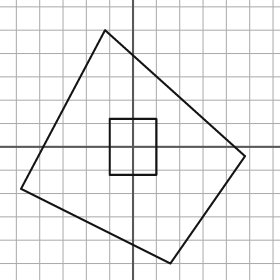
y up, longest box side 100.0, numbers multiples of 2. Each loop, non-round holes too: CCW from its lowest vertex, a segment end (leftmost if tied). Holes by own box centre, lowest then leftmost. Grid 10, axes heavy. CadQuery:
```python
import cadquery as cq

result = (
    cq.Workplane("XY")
    .moveTo(16.0, -50.0)
    .lineTo(48.0, -4.0)
    .lineTo(-12.0, 50.0)
    .lineTo(-48.0, -18.0)
    .close()
    .moveTo(-10.0, -12.0)
    .lineTo(10.0, -12.0)
    .lineTo(10.0, 12.0)
    .lineTo(-10.0, 12.0)
    .close()
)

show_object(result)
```